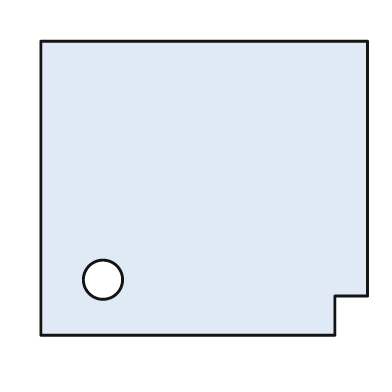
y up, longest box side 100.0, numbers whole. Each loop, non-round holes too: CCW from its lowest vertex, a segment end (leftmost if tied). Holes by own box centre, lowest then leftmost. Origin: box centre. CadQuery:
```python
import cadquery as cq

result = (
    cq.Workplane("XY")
    .moveTo(-50.0, -45.0)
    .lineTo(40.0, -45.0)
    .lineTo(40.0, -33.0)
    .lineTo(50.0, -33.0)
    .lineTo(50.0, 45.0)
    .lineTo(-50.0, 45.0)
    .close()
    .moveTo(-31.0, -28.0)
    .circle(6.0)
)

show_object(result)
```